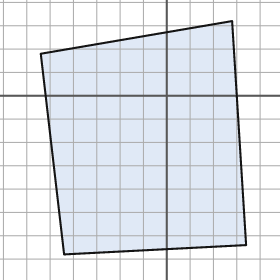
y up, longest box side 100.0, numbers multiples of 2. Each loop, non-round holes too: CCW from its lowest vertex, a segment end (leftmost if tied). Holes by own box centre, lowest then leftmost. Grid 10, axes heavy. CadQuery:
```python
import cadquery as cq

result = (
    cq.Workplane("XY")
    .moveTo(-44.0, -68.0)
    .lineTo(34.0, -64.0)
    .lineTo(28.0, 32.0)
    .lineTo(-54.0, 18.0)
    .close()
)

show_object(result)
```